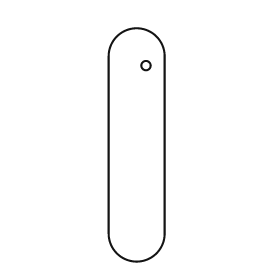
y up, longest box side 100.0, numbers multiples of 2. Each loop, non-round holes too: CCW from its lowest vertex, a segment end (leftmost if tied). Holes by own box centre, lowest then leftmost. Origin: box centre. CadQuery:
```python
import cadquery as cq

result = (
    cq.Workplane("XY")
    .moveTo(-12.0, -38.0)
    .threePointArc((0.0, -50.0), (12.0, -38.0))
    .lineTo(12.0, 38.0)
    .threePointArc((0.0, 50.0), (-12.0, 38.0))
    .close()
    .moveTo(4.0, 34.0)
    .circle(2.0)
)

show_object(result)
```